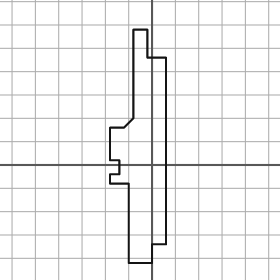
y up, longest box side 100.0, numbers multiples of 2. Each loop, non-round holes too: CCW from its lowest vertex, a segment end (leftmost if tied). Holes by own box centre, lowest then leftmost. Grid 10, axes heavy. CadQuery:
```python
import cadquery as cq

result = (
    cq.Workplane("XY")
    .moveTo(-10.0, -42.0)
    .lineTo(0.0, -42.0)
    .lineTo(0.0, -34.0)
    .lineTo(6.0, -34.0)
    .lineTo(6.0, 46.0)
    .lineTo(-2.0, 46.0)
    .lineTo(-2.0, 58.0)
    .lineTo(-8.0, 58.0)
    .lineTo(-8.0, 20.0)
    .lineTo(-12.0, 16.0)
    .lineTo(-18.0, 16.0)
    .lineTo(-18.0, 2.0)
    .lineTo(-14.0, 2.0)
    .lineTo(-14.0, -4.0)
    .lineTo(-18.0, -4.0)
    .lineTo(-18.0, -8.0)
    .lineTo(-10.0, -8.0)
    .close()
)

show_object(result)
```